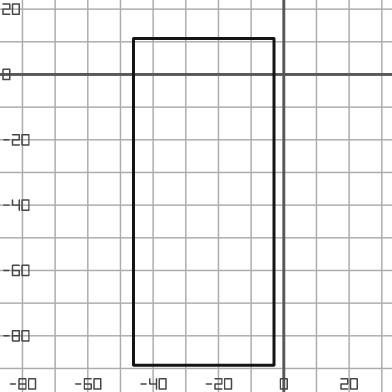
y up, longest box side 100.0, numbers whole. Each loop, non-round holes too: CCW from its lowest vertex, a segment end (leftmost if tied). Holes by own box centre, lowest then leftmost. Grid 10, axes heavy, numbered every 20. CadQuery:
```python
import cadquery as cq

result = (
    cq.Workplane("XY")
    .moveTo(-46.0, -89.0)
    .lineTo(-3.0, -89.0)
    .lineTo(-3.0, 11.0)
    .lineTo(-46.0, 11.0)
    .close()
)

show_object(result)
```